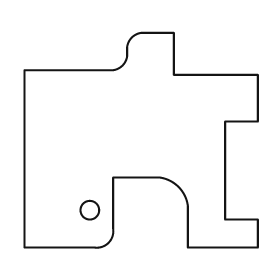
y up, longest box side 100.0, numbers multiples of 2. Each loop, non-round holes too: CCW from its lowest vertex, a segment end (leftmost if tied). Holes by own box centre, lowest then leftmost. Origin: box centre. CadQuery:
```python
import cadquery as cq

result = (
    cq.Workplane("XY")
    .moveTo(-50.0, -46.0)
    .lineTo(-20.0, -46.0)
    .threePointArc((-14.0, -44.0), (-12.0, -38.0))
    .lineTo(-12.0, -16.0)
    .lineTo(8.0, -16.0)
    .threePointArc((16.0, -20.0), (20.0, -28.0))
    .lineTo(20.0, -46.0)
    .lineTo(50.0, -46.0)
    .lineTo(50.0, -34.0)
    .lineTo(36.0, -34.0)
    .lineTo(36.0, 8.0)
    .lineTo(50.0, 8.0)
    .lineTo(50.0, 28.0)
    .lineTo(14.0, 28.0)
    .lineTo(14.0, 46.0)
    .lineTo(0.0, 46.0)
    .threePointArc((-4.0, 44.0), (-6.0, 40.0))
    .lineTo(-6.0, 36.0)
    .threePointArc((-8.0, 32.0), (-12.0, 30.0))
    .lineTo(-50.0, 30.0)
    .close()
    .moveTo(-22.0, -30.0)
    .circle(4.0)
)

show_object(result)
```